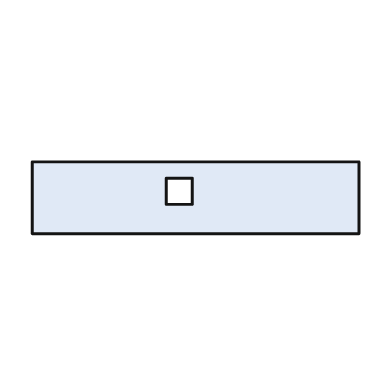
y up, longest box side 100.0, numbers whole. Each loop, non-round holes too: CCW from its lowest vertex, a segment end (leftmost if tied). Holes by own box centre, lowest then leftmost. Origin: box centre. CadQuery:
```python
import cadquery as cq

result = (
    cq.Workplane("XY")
    .moveTo(-50.0, -11.0)
    .lineTo(50.0, -11.0)
    .lineTo(50.0, 11.0)
    .lineTo(-50.0, 11.0)
    .close()
    .moveTo(-9.0, -2.0)
    .lineTo(-1.0, -2.0)
    .lineTo(-1.0, 6.0)
    .lineTo(-9.0, 6.0)
    .close()
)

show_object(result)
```